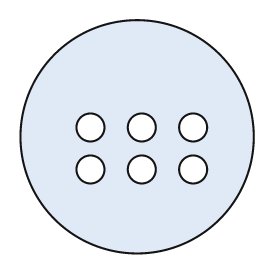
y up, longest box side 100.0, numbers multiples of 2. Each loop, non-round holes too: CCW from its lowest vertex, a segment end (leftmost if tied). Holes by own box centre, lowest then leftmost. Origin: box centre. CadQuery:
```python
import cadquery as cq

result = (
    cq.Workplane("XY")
    .moveTo(0.0, 0.0)
    .circle(50.0)
    .moveTo(-20.0, -14.0)
    .circle(6.0)
    .moveTo(2.0, -14.0)
    .circle(6.0)
    .moveTo(24.0, -14.0)
    .circle(6.0)
    .moveTo(-20.0, 4.0)
    .circle(6.0)
    .moveTo(2.0, 4.0)
    .circle(6.0)
    .moveTo(24.0, 4.0)
    .circle(6.0)
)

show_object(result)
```